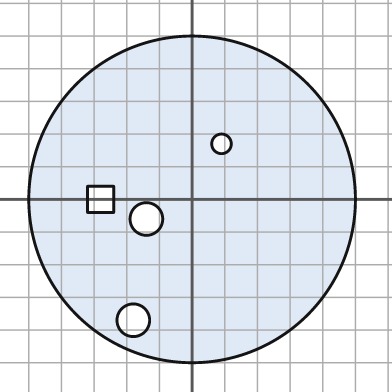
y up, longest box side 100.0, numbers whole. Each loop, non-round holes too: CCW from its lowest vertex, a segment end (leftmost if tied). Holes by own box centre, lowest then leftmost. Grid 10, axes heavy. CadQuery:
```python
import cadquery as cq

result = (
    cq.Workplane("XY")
    .moveTo(0.0, 0.0)
    .circle(50.0)
    .moveTo(-18.0, -37.0)
    .circle(5.0)
    .moveTo(-14.0, -6.0)
    .circle(5.0)
    .moveTo(-32.0, -4.0)
    .lineTo(-24.0, -4.0)
    .lineTo(-24.0, 4.0)
    .lineTo(-32.0, 4.0)
    .close()
    .moveTo(9.0, 17.0)
    .circle(3.0)
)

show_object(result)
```